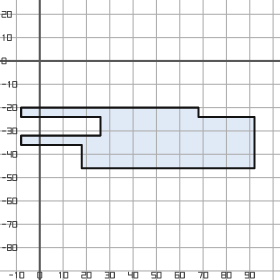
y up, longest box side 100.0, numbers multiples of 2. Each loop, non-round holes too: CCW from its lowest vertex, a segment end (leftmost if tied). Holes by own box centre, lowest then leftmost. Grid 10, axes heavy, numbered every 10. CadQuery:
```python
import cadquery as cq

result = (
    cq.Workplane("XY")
    .moveTo(18.0, -46.0)
    .lineTo(92.0, -46.0)
    .lineTo(92.0, -24.0)
    .lineTo(68.0, -24.0)
    .lineTo(68.0, -20.0)
    .lineTo(-8.0, -20.0)
    .lineTo(-8.0, -24.0)
    .lineTo(26.0, -24.0)
    .lineTo(26.0, -32.0)
    .lineTo(-8.0, -32.0)
    .lineTo(-8.0, -36.0)
    .lineTo(18.0, -36.0)
    .close()
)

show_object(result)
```